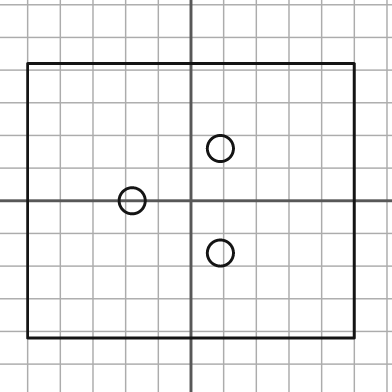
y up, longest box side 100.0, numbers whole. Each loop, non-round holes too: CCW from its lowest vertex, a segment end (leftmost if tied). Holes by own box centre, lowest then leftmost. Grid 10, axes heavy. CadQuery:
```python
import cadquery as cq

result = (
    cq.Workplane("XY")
    .moveTo(-50.0, -42.0)
    .lineTo(50.0, -42.0)
    .lineTo(50.0, 42.0)
    .lineTo(-50.0, 42.0)
    .close()
    .moveTo(9.0, -16.0)
    .circle(4.0)
    .moveTo(-18.0, 0.0)
    .circle(4.0)
    .moveTo(9.0, 16.0)
    .circle(4.0)
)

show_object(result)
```